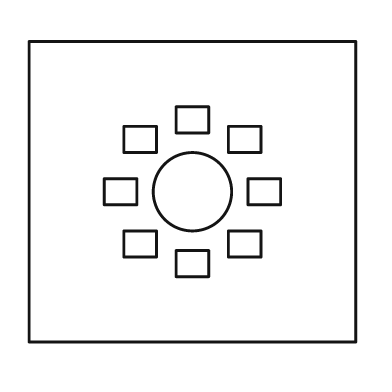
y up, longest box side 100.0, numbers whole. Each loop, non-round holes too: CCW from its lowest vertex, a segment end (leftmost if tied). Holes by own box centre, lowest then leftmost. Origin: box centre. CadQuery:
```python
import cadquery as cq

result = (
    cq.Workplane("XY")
    .moveTo(-50.0, -46.0)
    .lineTo(50.0, -46.0)
    .lineTo(50.0, 46.0)
    .lineTo(-50.0, 46.0)
    .close()
    .moveTo(-5.0, -26.0)
    .lineTo(5.0, -26.0)
    .lineTo(5.0, -18.0)
    .lineTo(-5.0, -18.0)
    .close()
    .moveTo(-21.0, -20.0)
    .lineTo(-11.0, -20.0)
    .lineTo(-11.0, -12.0)
    .lineTo(-21.0, -12.0)
    .close()
    .moveTo(11.0, -20.0)
    .lineTo(21.0, -20.0)
    .lineTo(21.0, -12.0)
    .lineTo(11.0, -12.0)
    .close()
    .moveTo(-27.0, -4.0)
    .lineTo(-17.0, -4.0)
    .lineTo(-17.0, 4.0)
    .lineTo(-27.0, 4.0)
    .close()
    .moveTo(0.0, 0.0)
    .circle(12.0)
    .moveTo(17.0, -4.0)
    .lineTo(27.0, -4.0)
    .lineTo(27.0, 4.0)
    .lineTo(17.0, 4.0)
    .close()
    .moveTo(-21.0, 12.0)
    .lineTo(-11.0, 12.0)
    .lineTo(-11.0, 20.0)
    .lineTo(-21.0, 20.0)
    .close()
    .moveTo(11.0, 12.0)
    .lineTo(21.0, 12.0)
    .lineTo(21.0, 20.0)
    .lineTo(11.0, 20.0)
    .close()
    .moveTo(-5.0, 18.0)
    .lineTo(5.0, 18.0)
    .lineTo(5.0, 26.0)
    .lineTo(-5.0, 26.0)
    .close()
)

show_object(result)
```